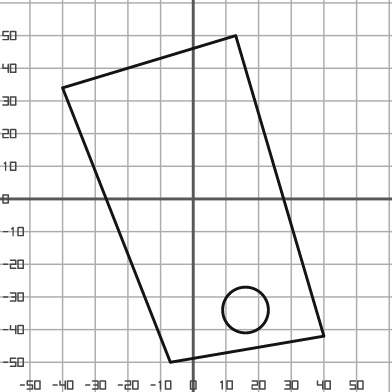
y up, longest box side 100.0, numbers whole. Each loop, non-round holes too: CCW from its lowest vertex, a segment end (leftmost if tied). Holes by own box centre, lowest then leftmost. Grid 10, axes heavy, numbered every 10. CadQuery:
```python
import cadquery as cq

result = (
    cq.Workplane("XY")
    .moveTo(-7.0, -50.0)
    .lineTo(40.0, -42.0)
    .lineTo(13.0, 50.0)
    .lineTo(-40.0, 34.0)
    .close()
    .moveTo(16.0, -34.0)
    .circle(7.0)
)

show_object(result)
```